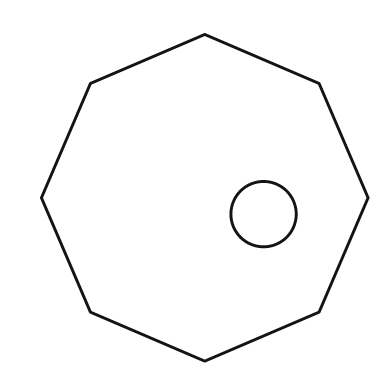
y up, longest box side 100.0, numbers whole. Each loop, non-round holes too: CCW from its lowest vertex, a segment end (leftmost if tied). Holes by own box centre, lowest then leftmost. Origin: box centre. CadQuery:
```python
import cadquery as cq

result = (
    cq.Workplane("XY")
    .moveTo(0.0, -50.0)
    .lineTo(35.0, -35.0)
    .lineTo(50.0, 0.0)
    .lineTo(35.0, 35.0)
    .lineTo(0.0, 50.0)
    .lineTo(-35.0, 35.0)
    .lineTo(-50.0, 0.0)
    .lineTo(-35.0, -35.0)
    .close()
    .moveTo(18.0, -5.0)
    .circle(10.0)
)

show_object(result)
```